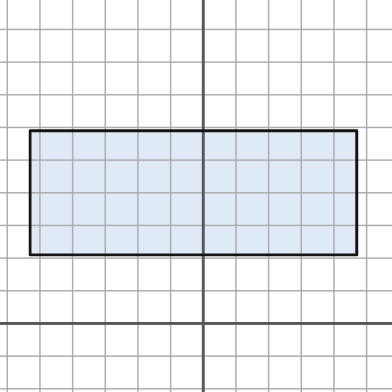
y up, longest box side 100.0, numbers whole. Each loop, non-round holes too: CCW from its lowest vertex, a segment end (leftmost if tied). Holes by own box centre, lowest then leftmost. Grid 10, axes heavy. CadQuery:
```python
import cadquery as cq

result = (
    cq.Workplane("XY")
    .moveTo(-53.0, 21.0)
    .lineTo(47.0, 21.0)
    .lineTo(47.0, 59.0)
    .lineTo(-53.0, 59.0)
    .close()
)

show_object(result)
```